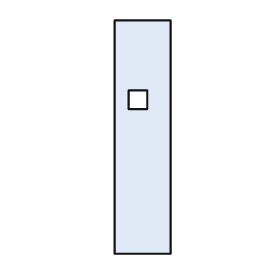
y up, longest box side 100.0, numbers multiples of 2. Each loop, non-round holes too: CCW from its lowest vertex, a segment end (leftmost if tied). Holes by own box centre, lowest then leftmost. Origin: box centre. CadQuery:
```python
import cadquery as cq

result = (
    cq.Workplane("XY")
    .moveTo(-12.0, -50.0)
    .lineTo(12.0, -50.0)
    .lineTo(12.0, 50.0)
    .lineTo(-12.0, 50.0)
    .close()
    .moveTo(-6.0, 12.0)
    .lineTo(2.0, 12.0)
    .lineTo(2.0, 20.0)
    .lineTo(-6.0, 20.0)
    .close()
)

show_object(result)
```